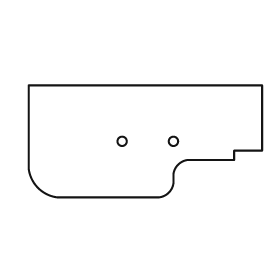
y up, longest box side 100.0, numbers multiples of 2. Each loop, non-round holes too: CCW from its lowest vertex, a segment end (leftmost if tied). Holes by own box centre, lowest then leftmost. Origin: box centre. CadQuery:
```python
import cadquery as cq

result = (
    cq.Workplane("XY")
    .moveTo(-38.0, -24.0)
    .lineTo(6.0, -24.0)
    .threePointArc((10.0, -22.0), (12.0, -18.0))
    .lineTo(12.0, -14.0)
    .threePointArc((14.0, -10.0), (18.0, -8.0))
    .lineTo(38.0, -8.0)
    .lineTo(38.0, -4.0)
    .lineTo(50.0, -4.0)
    .lineTo(50.0, 24.0)
    .lineTo(-50.0, 24.0)
    .lineTo(-50.0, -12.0)
    .threePointArc((-46.0, -20.0), (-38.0, -24.0))
    .close()
    .moveTo(-10.0, 0.0)
    .circle(2.0)
    .moveTo(12.0, 0.0)
    .circle(2.0)
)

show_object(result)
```